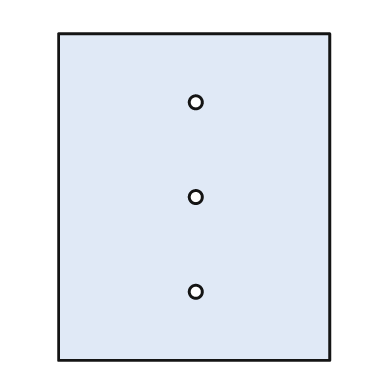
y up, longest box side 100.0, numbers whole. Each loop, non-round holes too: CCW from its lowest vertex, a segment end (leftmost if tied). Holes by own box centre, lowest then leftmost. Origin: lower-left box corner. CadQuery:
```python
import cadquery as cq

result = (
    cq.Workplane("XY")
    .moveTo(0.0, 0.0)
    .lineTo(83.0, 0.0)
    .lineTo(83.0, 100.0)
    .lineTo(0.0, 100.0)
    .close()
    .moveTo(42.0, 21.0)
    .circle(2.0)
    .moveTo(42.0, 50.0)
    .circle(2.0)
    .moveTo(42.0, 79.0)
    .circle(2.0)
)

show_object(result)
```